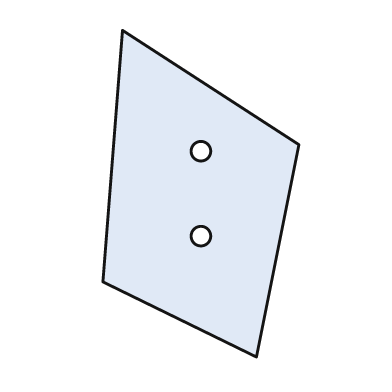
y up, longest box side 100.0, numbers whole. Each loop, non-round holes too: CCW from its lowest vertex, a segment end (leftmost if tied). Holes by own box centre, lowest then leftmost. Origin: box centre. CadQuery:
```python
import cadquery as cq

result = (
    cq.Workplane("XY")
    .moveTo(17.0, -50.0)
    .lineTo(30.0, 15.0)
    .lineTo(-24.0, 50.0)
    .lineTo(-30.0, -27.0)
    .close()
    .moveTo(0.0, -13.0)
    .circle(3.0)
    .moveTo(0.0, 13.0)
    .circle(3.0)
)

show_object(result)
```